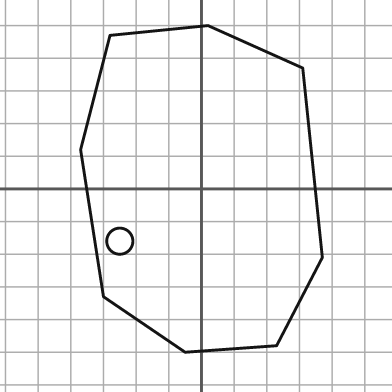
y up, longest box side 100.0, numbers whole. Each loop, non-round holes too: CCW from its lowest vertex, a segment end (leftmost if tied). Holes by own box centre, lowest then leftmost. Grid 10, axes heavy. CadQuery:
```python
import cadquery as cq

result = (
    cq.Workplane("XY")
    .moveTo(-5.0, -50.0)
    .lineTo(23.0, -48.0)
    .lineTo(37.0, -21.0)
    .lineTo(31.0, 37.0)
    .lineTo(2.0, 50.0)
    .lineTo(-28.0, 47.0)
    .lineTo(-37.0, 12.0)
    .lineTo(-30.0, -33.0)
    .close()
    .moveTo(-25.0, -16.0)
    .circle(4.0)
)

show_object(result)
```